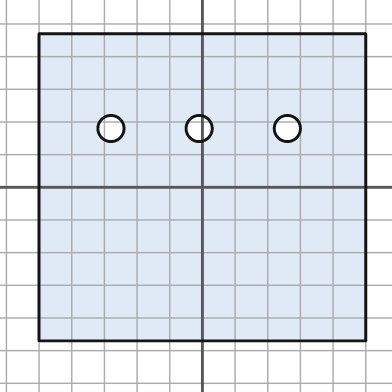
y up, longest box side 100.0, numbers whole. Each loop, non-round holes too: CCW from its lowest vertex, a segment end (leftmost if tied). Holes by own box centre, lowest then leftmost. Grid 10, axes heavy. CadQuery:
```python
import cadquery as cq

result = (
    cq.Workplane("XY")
    .moveTo(-50.0, -47.0)
    .lineTo(50.0, -47.0)
    .lineTo(50.0, 47.0)
    .lineTo(-50.0, 47.0)
    .close()
    .moveTo(-28.0, 18.0)
    .circle(4.0)
    .moveTo(-1.0, 18.0)
    .circle(4.0)
    .moveTo(26.0, 18.0)
    .circle(4.0)
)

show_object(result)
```